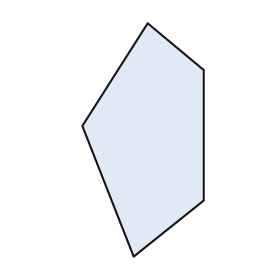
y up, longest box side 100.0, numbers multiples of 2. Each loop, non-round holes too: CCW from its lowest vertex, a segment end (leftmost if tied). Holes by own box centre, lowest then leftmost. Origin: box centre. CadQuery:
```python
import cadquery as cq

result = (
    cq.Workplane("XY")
    .moveTo(-4.0, -50.0)
    .lineTo(26.0, -26.0)
    .lineTo(26.0, 30.0)
    .lineTo(2.0, 50.0)
    .lineTo(-26.0, 6.0)
    .close()
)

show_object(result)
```